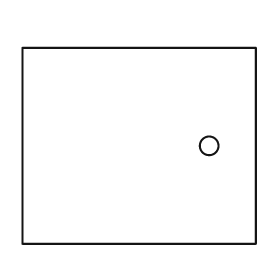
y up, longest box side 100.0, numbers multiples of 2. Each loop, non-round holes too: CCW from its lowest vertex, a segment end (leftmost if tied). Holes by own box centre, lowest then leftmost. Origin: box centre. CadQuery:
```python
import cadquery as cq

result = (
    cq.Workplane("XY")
    .moveTo(-50.0, -42.0)
    .lineTo(50.0, -42.0)
    .lineTo(50.0, 42.0)
    .lineTo(-50.0, 42.0)
    .close()
    .moveTo(30.0, 0.0)
    .circle(4.0)
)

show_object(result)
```